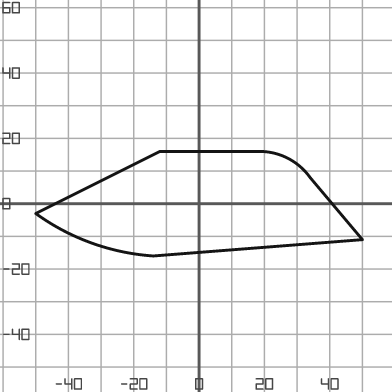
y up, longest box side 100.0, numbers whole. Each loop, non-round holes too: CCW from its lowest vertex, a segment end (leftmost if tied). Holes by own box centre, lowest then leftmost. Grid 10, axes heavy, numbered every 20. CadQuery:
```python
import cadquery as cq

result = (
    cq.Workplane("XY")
    .moveTo(-14.0, -16.0)
    .lineTo(50.0, -11.0)
    .lineTo(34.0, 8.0)
    .threePointArc((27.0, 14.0), (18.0, 16.0))
    .lineTo(-12.0, 16.0)
    .lineTo(-50.0, -3.0)
    .threePointArc((-33.0, -12.0), (-14.0, -16.0))
    .close()
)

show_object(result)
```